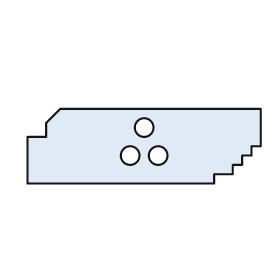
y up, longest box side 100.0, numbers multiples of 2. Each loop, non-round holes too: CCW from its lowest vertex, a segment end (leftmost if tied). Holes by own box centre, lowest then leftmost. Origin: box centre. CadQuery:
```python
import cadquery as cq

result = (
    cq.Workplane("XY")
    .moveTo(-50.0, -16.0)
    .lineTo(30.0, -16.0)
    .lineTo(30.0, -12.0)
    .lineTo(38.0, -12.0)
    .lineTo(38.0, -8.0)
    .lineTo(42.0, -8.0)
    .lineTo(42.0, -4.0)
    .lineTo(46.0, -4.0)
    .lineTo(46.0, 0.0)
    .lineTo(50.0, 0.0)
    .lineTo(50.0, 16.0)
    .lineTo(-36.0, 16.0)
    .lineTo(-42.0, 10.0)
    .lineTo(-42.0, 4.0)
    .lineTo(-50.0, 4.0)
    .close()
    .moveTo(-6.0, -4.0)
    .circle(4.0)
    .moveTo(6.0, -4.0)
    .circle(4.0)
    .moveTo(0.0, 8.0)
    .circle(4.0)
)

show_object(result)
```